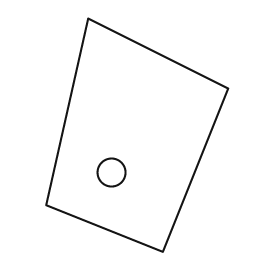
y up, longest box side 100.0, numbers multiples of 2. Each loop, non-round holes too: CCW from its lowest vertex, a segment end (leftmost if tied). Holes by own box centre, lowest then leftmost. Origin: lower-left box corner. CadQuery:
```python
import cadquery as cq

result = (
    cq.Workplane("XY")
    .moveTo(50.0, 0.0)
    .lineTo(78.0, 70.0)
    .lineTo(18.0, 100.0)
    .lineTo(0.0, 20.0)
    .close()
    .moveTo(28.0, 34.0)
    .circle(6.0)
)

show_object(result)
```